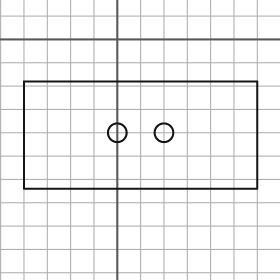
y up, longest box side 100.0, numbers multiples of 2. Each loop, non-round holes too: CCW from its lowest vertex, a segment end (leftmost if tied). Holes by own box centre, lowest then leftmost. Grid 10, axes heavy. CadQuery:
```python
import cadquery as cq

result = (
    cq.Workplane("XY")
    .moveTo(-40.0, -64.0)
    .lineTo(60.0, -64.0)
    .lineTo(60.0, -18.0)
    .lineTo(-40.0, -18.0)
    .close()
    .moveTo(0.0, -40.0)
    .circle(4.0)
    .moveTo(20.0, -40.0)
    .circle(4.0)
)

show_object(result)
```